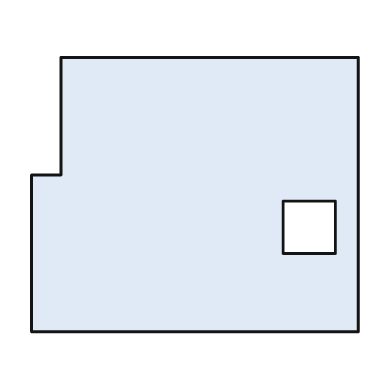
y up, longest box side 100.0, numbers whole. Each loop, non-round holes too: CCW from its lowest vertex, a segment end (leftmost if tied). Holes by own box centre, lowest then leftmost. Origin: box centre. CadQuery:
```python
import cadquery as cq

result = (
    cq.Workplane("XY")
    .moveTo(-50.0, -42.0)
    .lineTo(50.0, -42.0)
    .lineTo(50.0, 42.0)
    .lineTo(-41.0, 42.0)
    .lineTo(-41.0, 6.0)
    .lineTo(-50.0, 6.0)
    .close()
    .moveTo(27.0, -18.0)
    .lineTo(43.0, -18.0)
    .lineTo(43.0, -2.0)
    .lineTo(27.0, -2.0)
    .close()
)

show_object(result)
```